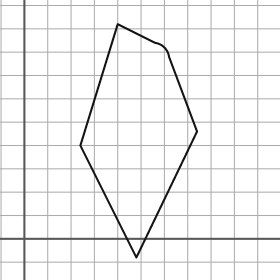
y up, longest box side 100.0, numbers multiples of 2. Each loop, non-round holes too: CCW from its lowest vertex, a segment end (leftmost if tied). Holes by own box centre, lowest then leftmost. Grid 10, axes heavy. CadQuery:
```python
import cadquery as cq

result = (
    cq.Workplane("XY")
    .moveTo(48.0, -8.0)
    .lineTo(74.0, 46.0)
    .lineTo(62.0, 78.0)
    .threePointArc((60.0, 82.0), (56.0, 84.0))
    .lineTo(40.0, 92.0)
    .lineTo(24.0, 40.0)
    .close()
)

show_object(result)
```